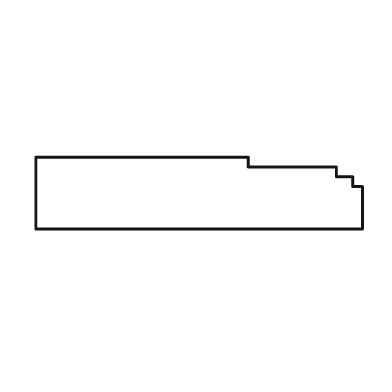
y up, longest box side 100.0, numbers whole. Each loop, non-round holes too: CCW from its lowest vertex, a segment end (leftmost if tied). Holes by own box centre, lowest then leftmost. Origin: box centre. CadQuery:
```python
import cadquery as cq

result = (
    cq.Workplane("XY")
    .moveTo(-50.0, -11.0)
    .lineTo(50.0, -11.0)
    .lineTo(50.0, 2.0)
    .lineTo(47.0, 2.0)
    .lineTo(47.0, 5.0)
    .lineTo(42.0, 5.0)
    .lineTo(42.0, 8.0)
    .lineTo(15.0, 8.0)
    .lineTo(15.0, 11.0)
    .lineTo(-50.0, 11.0)
    .close()
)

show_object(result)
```